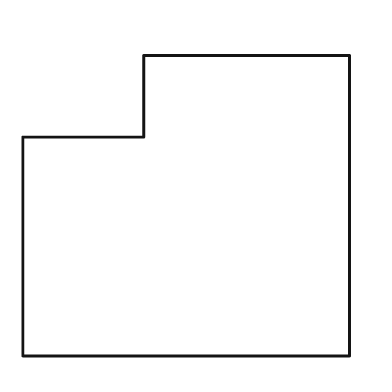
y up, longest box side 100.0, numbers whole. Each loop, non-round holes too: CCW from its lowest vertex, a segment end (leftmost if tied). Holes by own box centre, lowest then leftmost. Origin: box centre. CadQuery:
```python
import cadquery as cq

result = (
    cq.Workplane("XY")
    .moveTo(-50.0, -46.0)
    .lineTo(50.0, -46.0)
    .lineTo(50.0, 46.0)
    .lineTo(-13.0, 46.0)
    .lineTo(-13.0, 21.0)
    .lineTo(-50.0, 21.0)
    .close()
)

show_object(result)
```